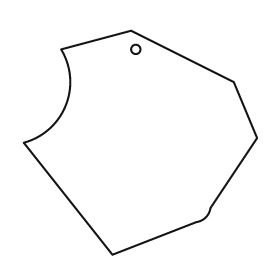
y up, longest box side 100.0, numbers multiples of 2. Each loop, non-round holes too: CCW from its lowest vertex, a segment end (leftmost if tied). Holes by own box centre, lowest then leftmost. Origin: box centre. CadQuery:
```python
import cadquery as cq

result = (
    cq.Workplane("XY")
    .moveTo(-12.0, -48.0)
    .lineTo(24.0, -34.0)
    .threePointArc((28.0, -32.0), (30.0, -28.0))
    .lineTo(50.0, 2.0)
    .lineTo(40.0, 26.0)
    .lineTo(-4.0, 48.0)
    .lineTo(-34.0, 40.0)
    .threePointArc((-32.0, 16.0), (-50.0, 0.0))
    .close()
    .moveTo(-2.0, 40.0)
    .circle(2.0)
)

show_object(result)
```